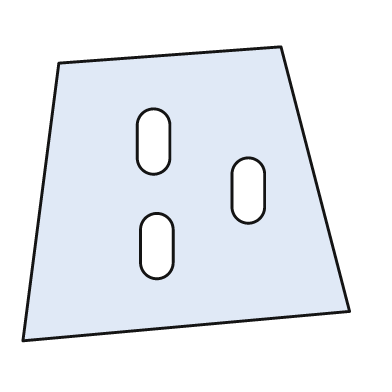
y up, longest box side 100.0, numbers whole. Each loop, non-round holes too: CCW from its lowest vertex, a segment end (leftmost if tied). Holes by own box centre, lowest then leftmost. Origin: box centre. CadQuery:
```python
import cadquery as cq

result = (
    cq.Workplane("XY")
    .moveTo(-50.0, -45.0)
    .lineTo(50.0, -36.0)
    .lineTo(29.0, 45.0)
    .lineTo(-39.0, 40.0)
    .close()
    .moveTo(-14.0, -21.0)
    .threePointArc((-9.0, -26.0), (-4.0, -21.0))
    .lineTo(-4.0, -11.0)
    .threePointArc((-9.0, -6.0), (-14.0, -11.0))
    .close()
    .moveTo(14.0, -4.0)
    .threePointArc((19.0, -9.0), (24.0, -4.0))
    .lineTo(24.0, 6.0)
    .threePointArc((19.0, 11.0), (14.0, 6.0))
    .close()
    .moveTo(-15.0, 11.0)
    .threePointArc((-10.0, 6.0), (-5.0, 11.0))
    .lineTo(-5.0, 21.0)
    .threePointArc((-10.0, 26.0), (-15.0, 21.0))
    .close()
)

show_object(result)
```